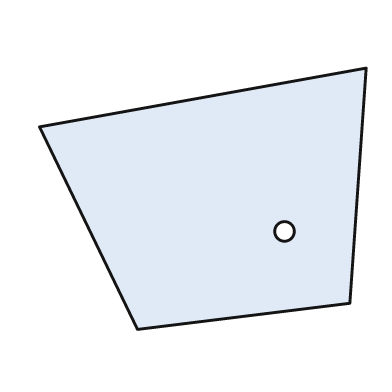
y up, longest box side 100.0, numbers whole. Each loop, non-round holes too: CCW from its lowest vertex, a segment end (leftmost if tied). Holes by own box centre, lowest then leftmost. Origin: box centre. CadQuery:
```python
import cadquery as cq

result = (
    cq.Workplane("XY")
    .moveTo(-20.0, -40.0)
    .lineTo(45.0, -32.0)
    .lineTo(50.0, 40.0)
    .lineTo(-50.0, 22.0)
    .close()
    .moveTo(25.0, -10.0)
    .circle(3.0)
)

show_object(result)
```